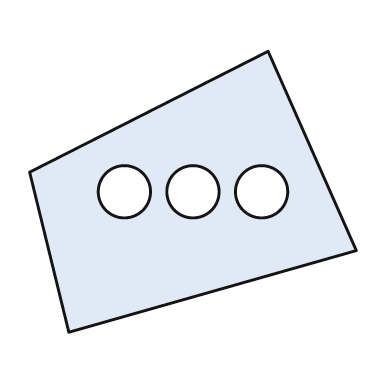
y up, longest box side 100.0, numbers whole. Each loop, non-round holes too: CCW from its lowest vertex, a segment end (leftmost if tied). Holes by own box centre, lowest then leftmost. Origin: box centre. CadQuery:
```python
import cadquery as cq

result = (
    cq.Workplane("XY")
    .moveTo(-38.0, -43.0)
    .lineTo(50.0, -18.0)
    .lineTo(23.0, 43.0)
    .lineTo(-50.0, 6.0)
    .close()
    .moveTo(-21.0, 0.0)
    .circle(8.0)
    .moveTo(0.0, 0.0)
    .circle(8.0)
    .moveTo(21.0, 0.0)
    .circle(8.0)
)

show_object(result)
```